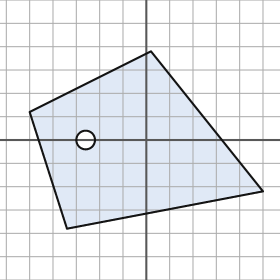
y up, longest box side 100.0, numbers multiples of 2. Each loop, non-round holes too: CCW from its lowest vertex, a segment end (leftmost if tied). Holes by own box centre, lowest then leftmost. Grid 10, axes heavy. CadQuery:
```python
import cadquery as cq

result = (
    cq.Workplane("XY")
    .moveTo(-34.0, -38.0)
    .lineTo(50.0, -22.0)
    .lineTo(2.0, 38.0)
    .lineTo(-50.0, 12.0)
    .close()
    .moveTo(-26.0, 0.0)
    .circle(4.0)
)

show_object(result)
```